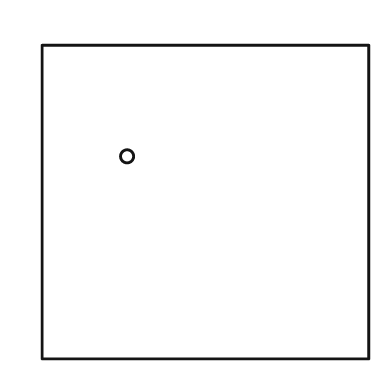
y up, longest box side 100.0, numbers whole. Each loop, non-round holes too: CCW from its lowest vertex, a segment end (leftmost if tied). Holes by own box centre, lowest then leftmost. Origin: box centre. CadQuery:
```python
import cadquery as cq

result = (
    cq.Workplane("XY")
    .moveTo(-50.0, -48.0)
    .lineTo(50.0, -48.0)
    .lineTo(50.0, 48.0)
    .lineTo(-50.0, 48.0)
    .close()
    .moveTo(-24.0, 14.0)
    .circle(2.0)
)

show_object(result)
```